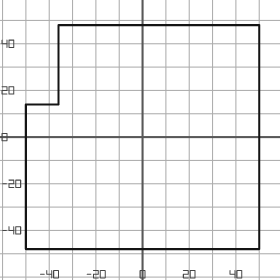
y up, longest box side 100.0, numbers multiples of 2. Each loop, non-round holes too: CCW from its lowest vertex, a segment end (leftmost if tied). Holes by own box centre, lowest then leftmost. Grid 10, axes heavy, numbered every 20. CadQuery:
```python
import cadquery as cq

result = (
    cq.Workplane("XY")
    .moveTo(-50.0, -48.0)
    .lineTo(50.0, -48.0)
    .lineTo(50.0, 48.0)
    .lineTo(-36.0, 48.0)
    .lineTo(-36.0, 14.0)
    .lineTo(-50.0, 14.0)
    .close()
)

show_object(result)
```